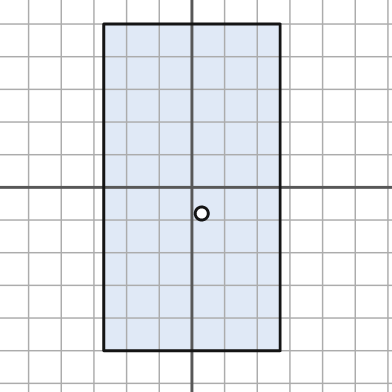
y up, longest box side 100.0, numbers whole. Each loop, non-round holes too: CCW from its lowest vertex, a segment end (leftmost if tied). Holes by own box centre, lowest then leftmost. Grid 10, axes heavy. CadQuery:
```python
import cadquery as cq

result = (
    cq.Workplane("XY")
    .moveTo(-27.0, -50.0)
    .lineTo(27.0, -50.0)
    .lineTo(27.0, 50.0)
    .lineTo(-27.0, 50.0)
    .close()
    .moveTo(3.0, -8.0)
    .circle(2.0)
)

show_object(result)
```